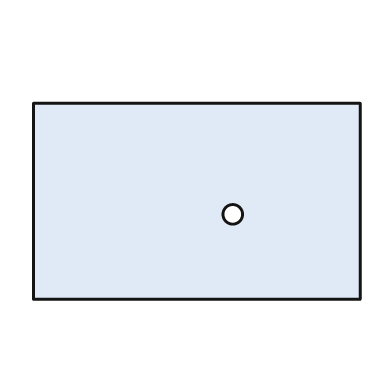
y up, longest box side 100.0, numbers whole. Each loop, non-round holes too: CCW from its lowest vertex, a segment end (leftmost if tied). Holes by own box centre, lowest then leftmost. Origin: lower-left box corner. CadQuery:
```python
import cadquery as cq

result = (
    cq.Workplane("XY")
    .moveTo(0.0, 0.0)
    .lineTo(100.0, 0.0)
    .lineTo(100.0, 60.0)
    .lineTo(0.0, 60.0)
    .close()
    .moveTo(61.0, 26.0)
    .circle(3.0)
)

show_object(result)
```